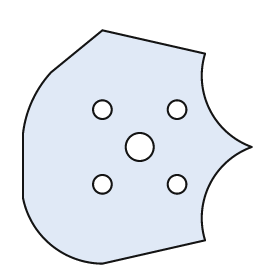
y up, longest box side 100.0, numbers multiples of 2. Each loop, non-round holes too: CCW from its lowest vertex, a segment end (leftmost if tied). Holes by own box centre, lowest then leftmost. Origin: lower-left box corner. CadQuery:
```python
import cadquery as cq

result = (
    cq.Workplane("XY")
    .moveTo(34.0, 0.0)
    .lineTo(78.0, 10.0)
    .threePointArc((80.0, 34.0), (98.0, 50.0))
    .threePointArc((80.0, 66.0), (78.0, 90.0))
    .lineTo(34.0, 100.0)
    .lineTo(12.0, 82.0)
    .threePointArc((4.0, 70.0), (0.0, 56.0))
    .lineTo(0.0, 28.0)
    .threePointArc((12.0, 8.0), (34.0, 0.0))
    .close()
    .moveTo(34.0, 34.0)
    .circle(4.0)
    .moveTo(66.0, 34.0)
    .circle(4.0)
    .moveTo(50.0, 50.0)
    .circle(6.0)
    .moveTo(34.0, 66.0)
    .circle(4.0)
    .moveTo(66.0, 66.0)
    .circle(4.0)
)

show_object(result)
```